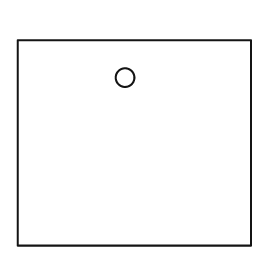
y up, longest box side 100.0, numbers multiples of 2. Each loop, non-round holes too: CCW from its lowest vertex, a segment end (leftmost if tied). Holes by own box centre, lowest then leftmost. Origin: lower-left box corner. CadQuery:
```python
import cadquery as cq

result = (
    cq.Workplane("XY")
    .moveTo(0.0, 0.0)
    .lineTo(100.0, 0.0)
    .lineTo(100.0, 88.0)
    .lineTo(0.0, 88.0)
    .close()
    .moveTo(46.0, 72.0)
    .circle(4.0)
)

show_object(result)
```